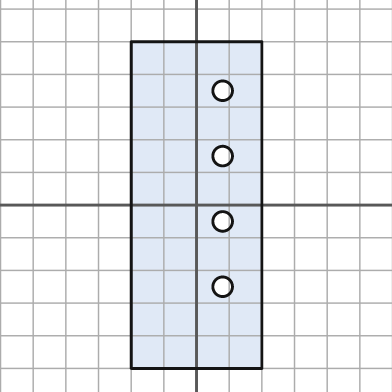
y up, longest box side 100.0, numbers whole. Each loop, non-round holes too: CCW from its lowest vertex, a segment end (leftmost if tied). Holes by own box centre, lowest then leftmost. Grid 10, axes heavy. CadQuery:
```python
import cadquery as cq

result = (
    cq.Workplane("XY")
    .moveTo(-20.0, -50.0)
    .lineTo(20.0, -50.0)
    .lineTo(20.0, 50.0)
    .lineTo(-20.0, 50.0)
    .close()
    .moveTo(8.0, -25.0)
    .circle(3.0)
    .moveTo(8.0, -5.0)
    .circle(3.0)
    .moveTo(8.0, 15.0)
    .circle(3.0)
    .moveTo(8.0, 35.0)
    .circle(3.0)
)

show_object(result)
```